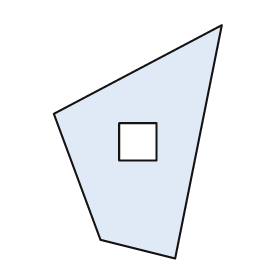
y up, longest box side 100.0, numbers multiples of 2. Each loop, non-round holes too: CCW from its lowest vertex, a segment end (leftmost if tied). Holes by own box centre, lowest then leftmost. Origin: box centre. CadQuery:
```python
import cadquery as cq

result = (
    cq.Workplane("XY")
    .moveTo(16.0, -50.0)
    .lineTo(36.0, 50.0)
    .lineTo(-36.0, 12.0)
    .lineTo(-16.0, -42.0)
    .close()
    .moveTo(-8.0, -8.0)
    .lineTo(8.0, -8.0)
    .lineTo(8.0, 8.0)
    .lineTo(-8.0, 8.0)
    .close()
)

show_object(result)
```